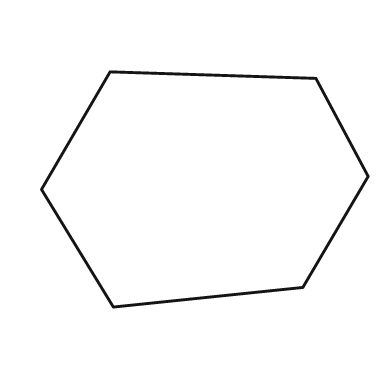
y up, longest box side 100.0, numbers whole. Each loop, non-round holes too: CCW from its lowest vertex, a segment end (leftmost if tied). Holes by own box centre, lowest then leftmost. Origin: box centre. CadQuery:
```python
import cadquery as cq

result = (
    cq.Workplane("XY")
    .moveTo(-28.0, -36.0)
    .lineTo(30.0, -30.0)
    .lineTo(50.0, 4.0)
    .lineTo(34.0, 34.0)
    .lineTo(-29.0, 36.0)
    .lineTo(-50.0, 0.0)
    .close()
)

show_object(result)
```